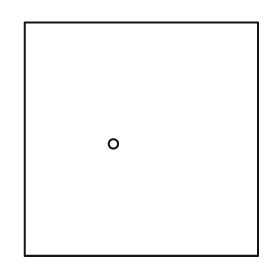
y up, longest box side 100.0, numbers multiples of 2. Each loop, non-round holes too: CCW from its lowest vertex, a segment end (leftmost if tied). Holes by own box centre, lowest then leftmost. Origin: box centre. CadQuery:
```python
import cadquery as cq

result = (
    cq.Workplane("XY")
    .moveTo(-50.0, -50.0)
    .lineTo(50.0, -50.0)
    .lineTo(50.0, 50.0)
    .lineTo(-50.0, 50.0)
    .close()
    .moveTo(-12.0, -2.0)
    .circle(2.0)
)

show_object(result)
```